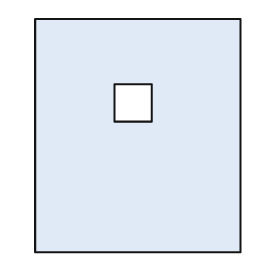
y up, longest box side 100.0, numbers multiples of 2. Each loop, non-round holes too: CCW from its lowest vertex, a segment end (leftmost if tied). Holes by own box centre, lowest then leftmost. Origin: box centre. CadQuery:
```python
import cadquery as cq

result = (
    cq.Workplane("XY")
    .moveTo(-44.0, -50.0)
    .lineTo(44.0, -50.0)
    .lineTo(44.0, 50.0)
    .lineTo(-44.0, 50.0)
    .close()
    .moveTo(-10.0, 6.0)
    .lineTo(6.0, 6.0)
    .lineTo(6.0, 22.0)
    .lineTo(-10.0, 22.0)
    .close()
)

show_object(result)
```